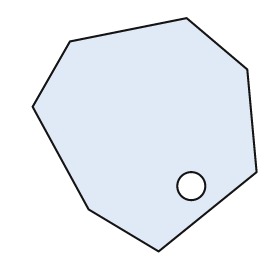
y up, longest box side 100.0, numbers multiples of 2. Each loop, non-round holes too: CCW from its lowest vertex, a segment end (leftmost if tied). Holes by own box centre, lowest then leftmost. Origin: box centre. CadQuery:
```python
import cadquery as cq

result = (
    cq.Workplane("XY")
    .moveTo(6.0, -50.0)
    .lineTo(48.0, -16.0)
    .lineTo(44.0, 28.0)
    .lineTo(18.0, 50.0)
    .lineTo(-32.0, 40.0)
    .lineTo(-48.0, 12.0)
    .lineTo(-24.0, -32.0)
    .close()
    .moveTo(20.0, -22.0)
    .circle(6.0)
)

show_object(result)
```